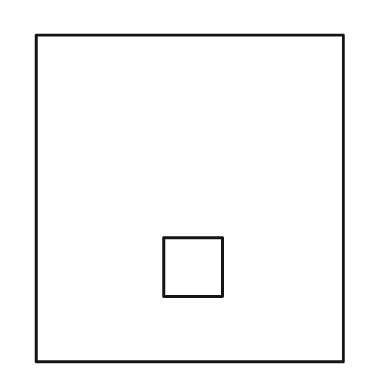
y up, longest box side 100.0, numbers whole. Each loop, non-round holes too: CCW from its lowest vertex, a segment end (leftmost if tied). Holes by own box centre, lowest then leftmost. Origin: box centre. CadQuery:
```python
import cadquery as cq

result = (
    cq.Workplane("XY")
    .moveTo(-47.0, -50.0)
    .lineTo(47.0, -50.0)
    .lineTo(47.0, 50.0)
    .lineTo(-47.0, 50.0)
    .close()
    .moveTo(-8.0, -30.0)
    .lineTo(10.0, -30.0)
    .lineTo(10.0, -12.0)
    .lineTo(-8.0, -12.0)
    .close()
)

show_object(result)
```